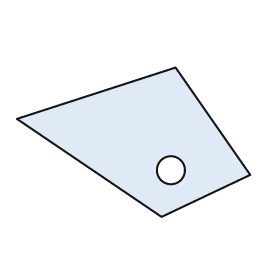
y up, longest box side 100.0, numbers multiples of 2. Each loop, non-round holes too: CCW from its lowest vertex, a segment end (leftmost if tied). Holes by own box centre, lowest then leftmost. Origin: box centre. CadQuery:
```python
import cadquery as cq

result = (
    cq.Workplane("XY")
    .moveTo(12.0, -32.0)
    .lineTo(50.0, -14.0)
    .lineTo(18.0, 32.0)
    .lineTo(-50.0, 10.0)
    .close()
    .moveTo(16.0, -12.0)
    .circle(6.0)
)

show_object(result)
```